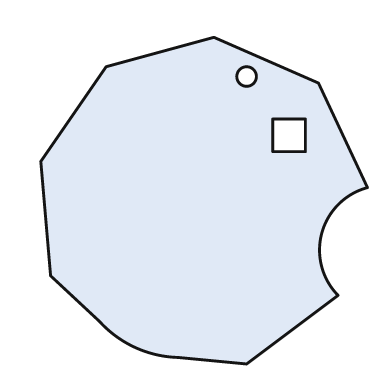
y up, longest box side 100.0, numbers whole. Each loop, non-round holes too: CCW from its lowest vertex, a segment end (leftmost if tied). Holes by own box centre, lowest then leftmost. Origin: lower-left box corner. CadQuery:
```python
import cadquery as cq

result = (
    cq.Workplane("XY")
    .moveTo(63.0, 0.0)
    .lineTo(91.0, 21.0)
    .threePointArc((86.0, 40.0), (100.0, 54.0))
    .lineTo(85.0, 86.0)
    .lineTo(53.0, 100.0)
    .lineTo(20.0, 91.0)
    .lineTo(0.0, 62.0)
    .lineTo(3.0, 27.0)
    .lineTo(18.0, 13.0)
    .threePointArc((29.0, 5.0), (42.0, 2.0))
    .close()
    .moveTo(71.0, 65.0)
    .lineTo(81.0, 65.0)
    .lineTo(81.0, 75.0)
    .lineTo(71.0, 75.0)
    .close()
    .moveTo(63.0, 88.0)
    .circle(3.0)
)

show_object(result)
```